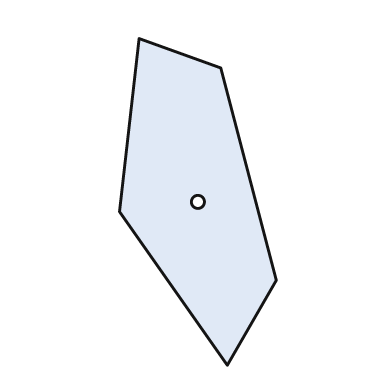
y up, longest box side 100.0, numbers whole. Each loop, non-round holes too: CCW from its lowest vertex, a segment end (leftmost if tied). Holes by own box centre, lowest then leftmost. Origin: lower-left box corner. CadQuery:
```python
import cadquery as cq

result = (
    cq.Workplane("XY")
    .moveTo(33.0, 0.0)
    .lineTo(48.0, 26.0)
    .lineTo(31.0, 91.0)
    .lineTo(6.0, 100.0)
    .lineTo(0.0, 47.0)
    .close()
    .moveTo(24.0, 50.0)
    .circle(2.0)
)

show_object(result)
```